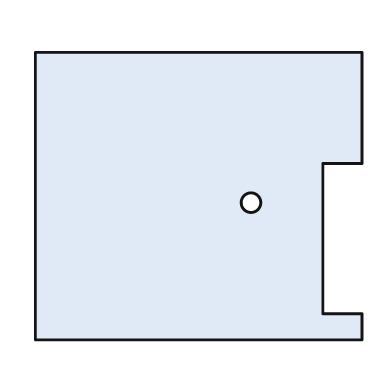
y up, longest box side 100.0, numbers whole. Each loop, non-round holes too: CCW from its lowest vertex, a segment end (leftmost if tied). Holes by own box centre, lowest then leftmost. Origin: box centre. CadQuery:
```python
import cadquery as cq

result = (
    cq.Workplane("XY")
    .moveTo(-50.0, -44.0)
    .lineTo(50.0, -44.0)
    .lineTo(50.0, -36.0)
    .lineTo(38.0, -36.0)
    .lineTo(38.0, 10.0)
    .lineTo(50.0, 10.0)
    .lineTo(50.0, 44.0)
    .lineTo(-50.0, 44.0)
    .close()
    .moveTo(16.0, -2.0)
    .circle(3.0)
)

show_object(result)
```